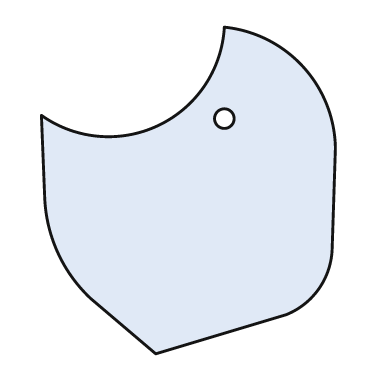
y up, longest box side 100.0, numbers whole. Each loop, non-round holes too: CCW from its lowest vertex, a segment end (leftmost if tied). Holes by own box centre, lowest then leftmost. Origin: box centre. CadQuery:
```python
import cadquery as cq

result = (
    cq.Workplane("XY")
    .moveTo(-10.0, -50.0)
    .lineTo(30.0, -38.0)
    .threePointArc((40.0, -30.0), (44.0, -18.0))
    .lineTo(45.0, 13.0)
    .threePointArc((35.0, 38.0), (11.0, 50.0))
    .threePointArc((-9.0, 20.0), (-45.0, 23.0))
    .lineTo(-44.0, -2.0)
    .threePointArc((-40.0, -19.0), (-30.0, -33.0))
    .close()
    .moveTo(11.0, 22.0)
    .circle(3.0)
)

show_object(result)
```